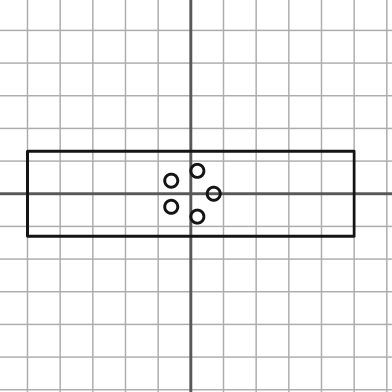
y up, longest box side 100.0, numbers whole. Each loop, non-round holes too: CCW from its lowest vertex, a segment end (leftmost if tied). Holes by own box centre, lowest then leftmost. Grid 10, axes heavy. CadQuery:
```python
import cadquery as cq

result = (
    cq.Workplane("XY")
    .moveTo(-50.0, -13.0)
    .lineTo(50.0, -13.0)
    .lineTo(50.0, 13.0)
    .lineTo(-50.0, 13.0)
    .close()
    .moveTo(2.0, -7.0)
    .circle(2.0)
    .moveTo(-6.0, -4.0)
    .circle(2.0)
    .moveTo(7.0, 0.0)
    .circle(2.0)
    .moveTo(-6.0, 4.0)
    .circle(2.0)
    .moveTo(2.0, 7.0)
    .circle(2.0)
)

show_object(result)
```